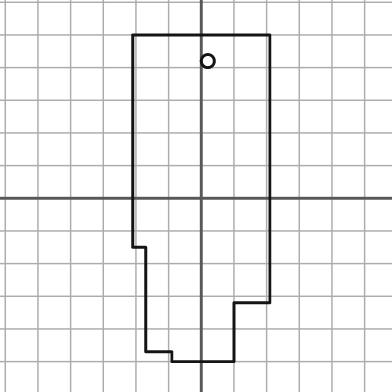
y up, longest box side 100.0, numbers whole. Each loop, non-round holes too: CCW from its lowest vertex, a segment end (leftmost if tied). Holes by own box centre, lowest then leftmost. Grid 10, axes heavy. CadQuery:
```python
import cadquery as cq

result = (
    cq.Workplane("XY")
    .moveTo(-9.0, -50.0)
    .lineTo(10.0, -50.0)
    .lineTo(10.0, -32.0)
    .lineTo(21.0, -32.0)
    .lineTo(21.0, 50.0)
    .lineTo(-21.0, 50.0)
    .lineTo(-21.0, -15.0)
    .lineTo(-17.0, -15.0)
    .lineTo(-17.0, -47.0)
    .lineTo(-9.0, -47.0)
    .close()
    .moveTo(2.0, 42.0)
    .circle(2.0)
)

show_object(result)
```